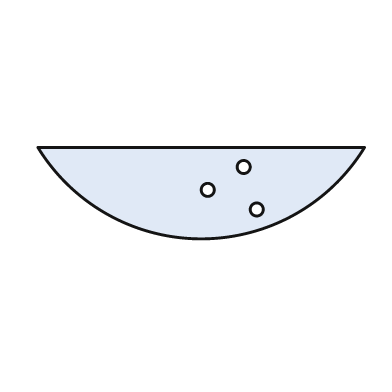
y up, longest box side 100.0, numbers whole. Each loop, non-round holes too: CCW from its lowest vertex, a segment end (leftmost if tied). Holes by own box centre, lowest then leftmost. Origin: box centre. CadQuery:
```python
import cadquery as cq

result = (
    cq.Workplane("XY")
    .moveTo(-50.0, 14.0)
    .threePointArc((0.0, -14.0), (50.0, 14.0))
    .close()
    .moveTo(17.0, -5.0)
    .circle(2.0)
    .moveTo(2.0, 1.0)
    .circle(2.0)
    .moveTo(13.0, 8.0)
    .circle(2.0)
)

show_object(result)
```